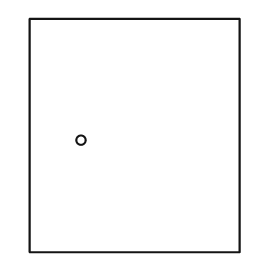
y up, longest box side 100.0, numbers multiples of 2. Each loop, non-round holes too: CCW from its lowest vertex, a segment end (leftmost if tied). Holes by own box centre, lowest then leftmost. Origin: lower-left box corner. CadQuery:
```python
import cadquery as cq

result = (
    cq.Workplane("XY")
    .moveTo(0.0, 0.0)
    .lineTo(90.0, 0.0)
    .lineTo(90.0, 100.0)
    .lineTo(0.0, 100.0)
    .close()
    .moveTo(22.0, 48.0)
    .circle(2.0)
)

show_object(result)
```